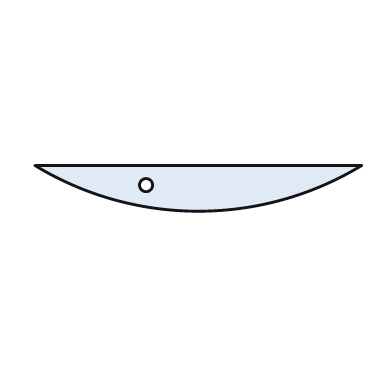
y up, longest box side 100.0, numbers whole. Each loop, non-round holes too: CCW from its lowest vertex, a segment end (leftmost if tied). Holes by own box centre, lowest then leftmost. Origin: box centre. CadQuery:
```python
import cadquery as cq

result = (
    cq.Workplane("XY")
    .moveTo(-50.0, 7.0)
    .threePointArc((0.0, -7.0), (50.0, 7.0))
    .close()
    .moveTo(-16.0, 1.0)
    .circle(2.0)
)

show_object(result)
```